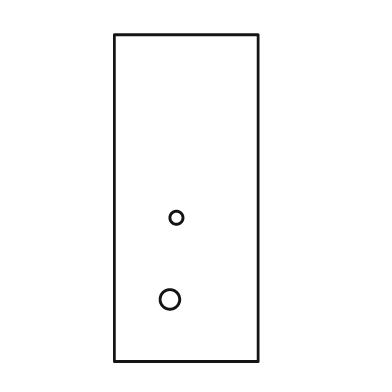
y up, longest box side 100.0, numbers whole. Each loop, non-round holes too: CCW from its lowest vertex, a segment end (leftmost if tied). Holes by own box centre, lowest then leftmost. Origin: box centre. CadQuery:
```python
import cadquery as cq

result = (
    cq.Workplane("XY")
    .moveTo(-22.0, -50.0)
    .lineTo(22.0, -50.0)
    .lineTo(22.0, 50.0)
    .lineTo(-22.0, 50.0)
    .close()
    .moveTo(-5.0, -31.0)
    .circle(3.0)
    .moveTo(-3.0, -6.0)
    .circle(2.0)
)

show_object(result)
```